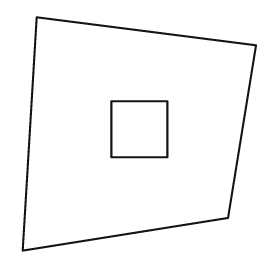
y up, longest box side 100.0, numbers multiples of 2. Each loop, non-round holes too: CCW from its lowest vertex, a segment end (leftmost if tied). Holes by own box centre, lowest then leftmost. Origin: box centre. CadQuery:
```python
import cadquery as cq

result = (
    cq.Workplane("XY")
    .moveTo(-50.0, -50.0)
    .lineTo(38.0, -36.0)
    .lineTo(50.0, 38.0)
    .lineTo(-44.0, 50.0)
    .close()
    .moveTo(-12.0, -10.0)
    .lineTo(12.0, -10.0)
    .lineTo(12.0, 14.0)
    .lineTo(-12.0, 14.0)
    .close()
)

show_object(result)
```